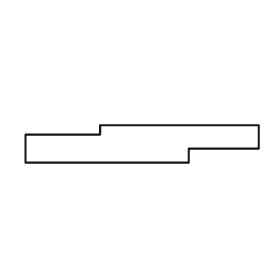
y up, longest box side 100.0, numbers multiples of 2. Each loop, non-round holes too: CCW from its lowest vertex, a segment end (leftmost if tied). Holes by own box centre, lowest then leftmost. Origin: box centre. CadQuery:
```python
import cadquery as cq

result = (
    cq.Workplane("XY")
    .moveTo(-50.0, -8.0)
    .lineTo(20.0, -8.0)
    .lineTo(20.0, -2.0)
    .lineTo(50.0, -2.0)
    .lineTo(50.0, 8.0)
    .lineTo(-18.0, 8.0)
    .lineTo(-18.0, 4.0)
    .lineTo(-50.0, 4.0)
    .close()
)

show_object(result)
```